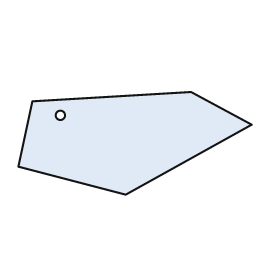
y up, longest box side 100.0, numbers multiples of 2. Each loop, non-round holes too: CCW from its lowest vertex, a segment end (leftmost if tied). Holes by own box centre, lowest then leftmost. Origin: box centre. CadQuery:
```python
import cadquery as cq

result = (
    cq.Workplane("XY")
    .moveTo(-4.0, -22.0)
    .lineTo(50.0, 8.0)
    .lineTo(24.0, 22.0)
    .lineTo(-44.0, 18.0)
    .lineTo(-50.0, -10.0)
    .close()
    .moveTo(-32.0, 12.0)
    .circle(2.0)
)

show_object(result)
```